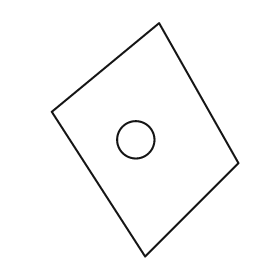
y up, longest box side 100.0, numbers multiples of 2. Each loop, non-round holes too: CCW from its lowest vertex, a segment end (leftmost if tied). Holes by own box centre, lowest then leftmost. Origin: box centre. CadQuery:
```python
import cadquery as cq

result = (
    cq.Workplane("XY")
    .moveTo(0.0, -50.0)
    .lineTo(40.0, -10.0)
    .lineTo(6.0, 50.0)
    .lineTo(-40.0, 12.0)
    .close()
    .moveTo(-4.0, 0.0)
    .circle(8.0)
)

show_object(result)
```